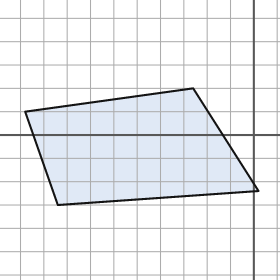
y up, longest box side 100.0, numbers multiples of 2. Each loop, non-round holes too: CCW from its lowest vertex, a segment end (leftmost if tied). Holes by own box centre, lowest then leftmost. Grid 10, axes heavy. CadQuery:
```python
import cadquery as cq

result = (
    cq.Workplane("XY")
    .moveTo(-84.0, -30.0)
    .lineTo(2.0, -24.0)
    .lineTo(-26.0, 20.0)
    .lineTo(-98.0, 10.0)
    .close()
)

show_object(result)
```